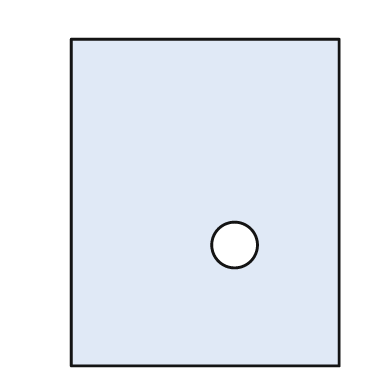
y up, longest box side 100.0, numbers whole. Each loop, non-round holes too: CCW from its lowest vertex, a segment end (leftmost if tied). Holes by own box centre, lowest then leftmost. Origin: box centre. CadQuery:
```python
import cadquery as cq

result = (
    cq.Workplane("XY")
    .moveTo(-41.0, -50.0)
    .lineTo(41.0, -50.0)
    .lineTo(41.0, 50.0)
    .lineTo(-41.0, 50.0)
    .close()
    .moveTo(9.0, -13.0)
    .circle(7.0)
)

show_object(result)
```